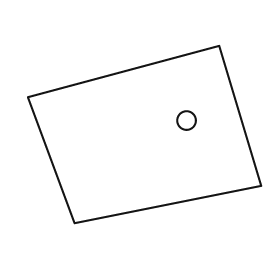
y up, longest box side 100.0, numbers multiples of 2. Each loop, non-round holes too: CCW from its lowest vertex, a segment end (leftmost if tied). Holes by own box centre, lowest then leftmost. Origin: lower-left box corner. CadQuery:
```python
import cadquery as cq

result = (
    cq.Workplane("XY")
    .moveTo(20.0, 0.0)
    .lineTo(100.0, 16.0)
    .lineTo(82.0, 76.0)
    .lineTo(0.0, 54.0)
    .close()
    .moveTo(68.0, 44.0)
    .circle(4.0)
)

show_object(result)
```